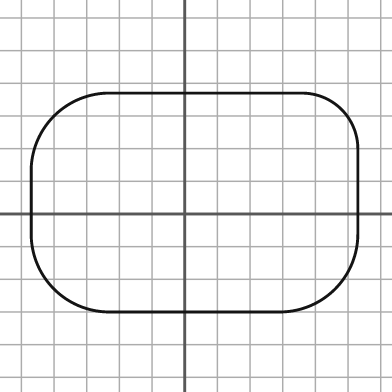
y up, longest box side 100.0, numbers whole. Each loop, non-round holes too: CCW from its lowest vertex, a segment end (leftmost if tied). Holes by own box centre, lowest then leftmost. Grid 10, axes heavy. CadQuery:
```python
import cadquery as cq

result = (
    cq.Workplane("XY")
    .moveTo(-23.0, -30.0)
    .lineTo(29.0, -30.0)
    .threePointArc((46.0, -23.0), (53.0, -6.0))
    .lineTo(53.0, 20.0)
    .threePointArc((48.0, 32.0), (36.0, 37.0))
    .lineTo(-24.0, 37.0)
    .threePointArc((-40.0, 30.0), (-47.0, 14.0))
    .lineTo(-47.0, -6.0)
    .threePointArc((-40.0, -23.0), (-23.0, -30.0))
    .close()
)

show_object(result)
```